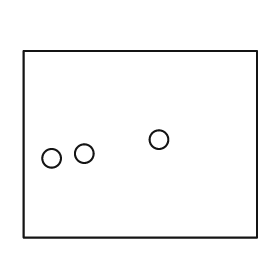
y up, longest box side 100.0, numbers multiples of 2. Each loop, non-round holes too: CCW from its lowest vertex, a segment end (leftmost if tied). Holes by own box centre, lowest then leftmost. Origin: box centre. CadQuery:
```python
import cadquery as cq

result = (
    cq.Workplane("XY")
    .moveTo(-50.0, -40.0)
    .lineTo(50.0, -40.0)
    .lineTo(50.0, 40.0)
    .lineTo(-50.0, 40.0)
    .close()
    .moveTo(-38.0, -6.0)
    .circle(4.0)
    .moveTo(-24.0, -4.0)
    .circle(4.0)
    .moveTo(8.0, 2.0)
    .circle(4.0)
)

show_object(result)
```